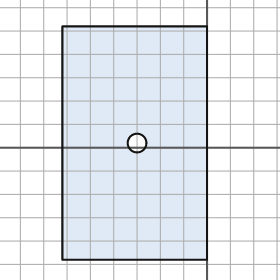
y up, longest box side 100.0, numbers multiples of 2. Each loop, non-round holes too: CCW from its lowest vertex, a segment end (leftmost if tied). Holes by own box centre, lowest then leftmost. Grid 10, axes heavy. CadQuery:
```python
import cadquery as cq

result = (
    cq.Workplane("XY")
    .moveTo(-62.0, -48.0)
    .lineTo(0.0, -48.0)
    .lineTo(0.0, 52.0)
    .lineTo(-62.0, 52.0)
    .close()
    .moveTo(-30.0, 2.0)
    .circle(4.0)
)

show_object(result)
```